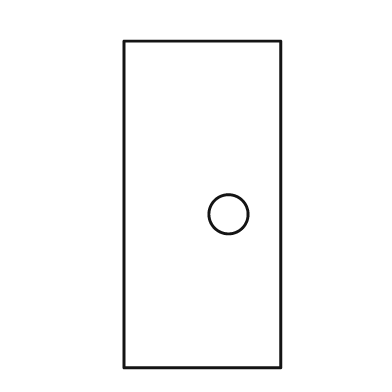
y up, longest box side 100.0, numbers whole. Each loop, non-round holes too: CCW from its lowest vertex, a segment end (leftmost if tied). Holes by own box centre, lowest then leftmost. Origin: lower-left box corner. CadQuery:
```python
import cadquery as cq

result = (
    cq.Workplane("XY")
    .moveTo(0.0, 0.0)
    .lineTo(48.0, 0.0)
    .lineTo(48.0, 100.0)
    .lineTo(0.0, 100.0)
    .close()
    .moveTo(32.0, 47.0)
    .circle(6.0)
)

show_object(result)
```